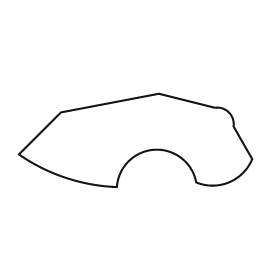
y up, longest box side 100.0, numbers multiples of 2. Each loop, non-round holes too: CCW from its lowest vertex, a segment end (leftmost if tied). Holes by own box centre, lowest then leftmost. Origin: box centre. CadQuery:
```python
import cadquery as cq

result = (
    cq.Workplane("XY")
    .moveTo(-8.0, -20.0)
    .threePointArc((8.0, -4.0), (26.0, -18.0))
    .threePointArc((40.0, -18.0), (50.0, -8.0))
    .lineTo(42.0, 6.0)
    .threePointArc((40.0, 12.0), (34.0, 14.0))
    .lineTo(10.0, 20.0)
    .lineTo(-32.0, 12.0)
    .lineTo(-50.0, -6.0)
    .threePointArc((-30.0, -16.0), (-8.0, -20.0))
    .close()
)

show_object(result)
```